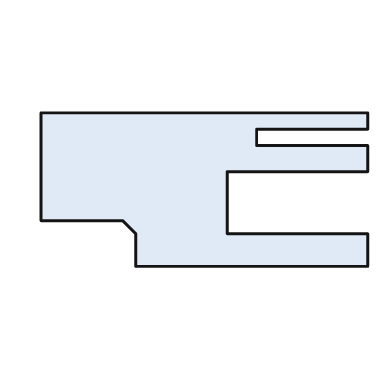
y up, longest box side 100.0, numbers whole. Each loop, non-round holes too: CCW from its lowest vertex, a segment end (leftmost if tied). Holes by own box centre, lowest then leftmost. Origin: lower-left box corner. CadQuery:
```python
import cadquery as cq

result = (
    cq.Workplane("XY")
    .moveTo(29.0, 0.0)
    .lineTo(100.0, 0.0)
    .lineTo(100.0, 10.0)
    .lineTo(57.0, 10.0)
    .lineTo(57.0, 29.0)
    .lineTo(100.0, 29.0)
    .lineTo(100.0, 37.0)
    .lineTo(66.0, 37.0)
    .lineTo(66.0, 42.0)
    .lineTo(100.0, 42.0)
    .lineTo(100.0, 47.0)
    .lineTo(0.0, 47.0)
    .lineTo(0.0, 14.0)
    .lineTo(25.0, 14.0)
    .lineTo(29.0, 10.0)
    .close()
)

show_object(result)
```